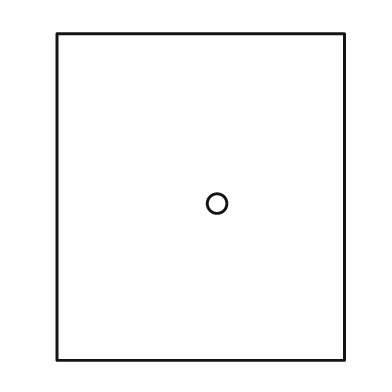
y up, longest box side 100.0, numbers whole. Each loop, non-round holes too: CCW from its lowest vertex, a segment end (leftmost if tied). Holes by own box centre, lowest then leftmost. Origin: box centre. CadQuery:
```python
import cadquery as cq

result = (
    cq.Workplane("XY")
    .moveTo(-44.0, -50.0)
    .lineTo(44.0, -50.0)
    .lineTo(44.0, 50.0)
    .lineTo(-44.0, 50.0)
    .close()
    .moveTo(5.0, -2.0)
    .circle(3.0)
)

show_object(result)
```